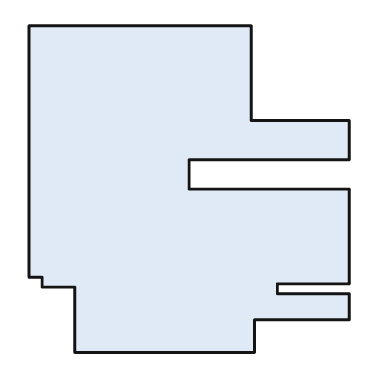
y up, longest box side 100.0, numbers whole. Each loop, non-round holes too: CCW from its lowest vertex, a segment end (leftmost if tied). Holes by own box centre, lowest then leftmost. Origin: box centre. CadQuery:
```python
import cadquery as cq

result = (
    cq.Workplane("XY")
    .moveTo(-35.0, -50.0)
    .lineTo(20.0, -50.0)
    .lineTo(20.0, -40.0)
    .lineTo(49.0, -40.0)
    .lineTo(49.0, -32.0)
    .lineTo(27.0, -32.0)
    .lineTo(27.0, -29.0)
    .lineTo(49.0, -29.0)
    .lineTo(49.0, 0.0)
    .lineTo(0.0, 0.0)
    .lineTo(0.0, 9.0)
    .lineTo(49.0, 9.0)
    .lineTo(49.0, 21.0)
    .lineTo(19.0, 21.0)
    .lineTo(19.0, 50.0)
    .lineTo(-49.0, 50.0)
    .lineTo(-49.0, -27.0)
    .lineTo(-45.0, -27.0)
    .lineTo(-45.0, -30.0)
    .lineTo(-35.0, -30.0)
    .close()
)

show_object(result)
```